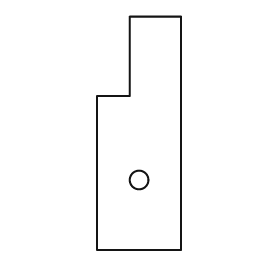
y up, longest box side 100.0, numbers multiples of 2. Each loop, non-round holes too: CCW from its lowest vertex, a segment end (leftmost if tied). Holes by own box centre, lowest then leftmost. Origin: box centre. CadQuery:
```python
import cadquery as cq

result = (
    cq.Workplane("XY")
    .moveTo(-18.0, -50.0)
    .lineTo(18.0, -50.0)
    .lineTo(18.0, 50.0)
    .lineTo(-4.0, 50.0)
    .lineTo(-4.0, 16.0)
    .lineTo(-18.0, 16.0)
    .close()
    .moveTo(0.0, -20.0)
    .circle(4.0)
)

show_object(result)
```